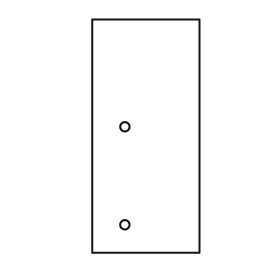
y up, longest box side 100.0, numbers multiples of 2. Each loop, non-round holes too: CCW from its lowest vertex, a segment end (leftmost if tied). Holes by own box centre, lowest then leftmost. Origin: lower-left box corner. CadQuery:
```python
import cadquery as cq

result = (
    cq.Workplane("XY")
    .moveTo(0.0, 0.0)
    .lineTo(46.0, 0.0)
    .lineTo(46.0, 100.0)
    .lineTo(0.0, 100.0)
    .close()
    .moveTo(14.0, 12.0)
    .circle(2.0)
    .moveTo(14.0, 54.0)
    .circle(2.0)
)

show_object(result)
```